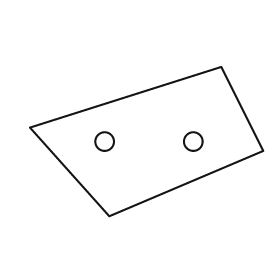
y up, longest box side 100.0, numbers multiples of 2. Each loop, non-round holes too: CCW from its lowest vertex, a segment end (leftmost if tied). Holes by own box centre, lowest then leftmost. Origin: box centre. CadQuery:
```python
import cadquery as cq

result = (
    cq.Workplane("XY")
    .moveTo(-16.0, -32.0)
    .lineTo(50.0, -4.0)
    .lineTo(32.0, 32.0)
    .lineTo(-50.0, 6.0)
    .close()
    .moveTo(-18.0, 0.0)
    .circle(4.0)
    .moveTo(20.0, 0.0)
    .circle(4.0)
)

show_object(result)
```